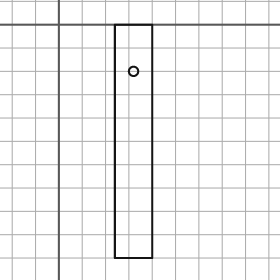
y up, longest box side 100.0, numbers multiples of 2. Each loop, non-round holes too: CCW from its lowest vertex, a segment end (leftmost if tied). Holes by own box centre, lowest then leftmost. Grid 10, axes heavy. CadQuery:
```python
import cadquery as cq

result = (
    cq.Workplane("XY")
    .moveTo(24.0, -100.0)
    .lineTo(40.0, -100.0)
    .lineTo(40.0, 0.0)
    .lineTo(24.0, 0.0)
    .close()
    .moveTo(32.0, -20.0)
    .circle(2.0)
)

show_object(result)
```